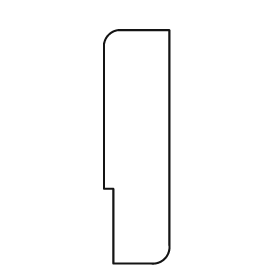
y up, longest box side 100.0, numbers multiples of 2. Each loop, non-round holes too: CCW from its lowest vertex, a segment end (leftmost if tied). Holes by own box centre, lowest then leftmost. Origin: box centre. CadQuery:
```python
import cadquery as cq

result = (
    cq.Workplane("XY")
    .moveTo(-10.0, -50.0)
    .lineTo(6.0, -50.0)
    .threePointArc((12.0, -48.0), (14.0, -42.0))
    .lineTo(14.0, 50.0)
    .lineTo(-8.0, 50.0)
    .threePointArc((-12.0, 48.0), (-14.0, 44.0))
    .lineTo(-14.0, -18.0)
    .lineTo(-10.0, -18.0)
    .close()
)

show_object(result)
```